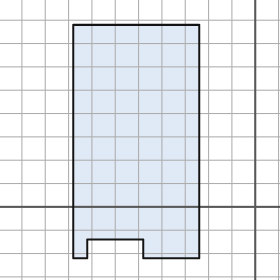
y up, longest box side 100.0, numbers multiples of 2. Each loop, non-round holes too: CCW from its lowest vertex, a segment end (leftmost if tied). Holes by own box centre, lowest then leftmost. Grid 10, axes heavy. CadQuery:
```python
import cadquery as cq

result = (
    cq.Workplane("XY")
    .moveTo(-78.0, -22.0)
    .lineTo(-72.0, -22.0)
    .lineTo(-72.0, -14.0)
    .lineTo(-48.0, -14.0)
    .lineTo(-48.0, -22.0)
    .lineTo(-24.0, -22.0)
    .lineTo(-24.0, 78.0)
    .lineTo(-78.0, 78.0)
    .close()
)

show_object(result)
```